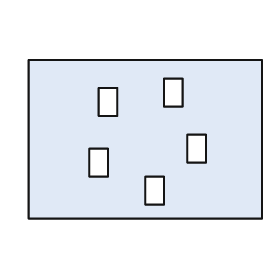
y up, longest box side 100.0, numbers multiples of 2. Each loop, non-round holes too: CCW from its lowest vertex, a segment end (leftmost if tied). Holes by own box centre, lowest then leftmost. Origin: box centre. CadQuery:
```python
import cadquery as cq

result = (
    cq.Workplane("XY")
    .moveTo(-50.0, -34.0)
    .lineTo(50.0, -34.0)
    .lineTo(50.0, 34.0)
    .lineTo(-50.0, 34.0)
    .close()
    .moveTo(0.0, -28.0)
    .lineTo(8.0, -28.0)
    .lineTo(8.0, -16.0)
    .lineTo(0.0, -16.0)
    .close()
    .moveTo(-24.0, -16.0)
    .lineTo(-16.0, -16.0)
    .lineTo(-16.0, -4.0)
    .lineTo(-24.0, -4.0)
    .close()
    .moveTo(18.0, -10.0)
    .lineTo(26.0, -10.0)
    .lineTo(26.0, 2.0)
    .lineTo(18.0, 2.0)
    .close()
    .moveTo(-20.0, 10.0)
    .lineTo(-12.0, 10.0)
    .lineTo(-12.0, 22.0)
    .lineTo(-20.0, 22.0)
    .close()
    .moveTo(8.0, 14.0)
    .lineTo(16.0, 14.0)
    .lineTo(16.0, 26.0)
    .lineTo(8.0, 26.0)
    .close()
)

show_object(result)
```